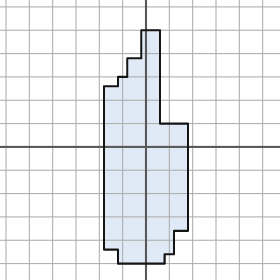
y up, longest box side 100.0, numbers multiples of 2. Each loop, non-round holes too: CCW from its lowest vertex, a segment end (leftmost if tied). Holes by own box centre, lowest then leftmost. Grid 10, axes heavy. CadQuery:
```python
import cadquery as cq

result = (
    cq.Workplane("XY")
    .moveTo(-12.0, -50.0)
    .lineTo(8.0, -50.0)
    .lineTo(8.0, -46.0)
    .lineTo(12.0, -46.0)
    .lineTo(12.0, -36.0)
    .lineTo(18.0, -36.0)
    .lineTo(18.0, 10.0)
    .lineTo(6.0, 10.0)
    .lineTo(6.0, 50.0)
    .lineTo(-2.0, 50.0)
    .lineTo(-2.0, 38.0)
    .lineTo(-8.0, 38.0)
    .lineTo(-8.0, 30.0)
    .lineTo(-12.0, 30.0)
    .lineTo(-12.0, 26.0)
    .lineTo(-18.0, 26.0)
    .lineTo(-18.0, -44.0)
    .lineTo(-12.0, -44.0)
    .close()
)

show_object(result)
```